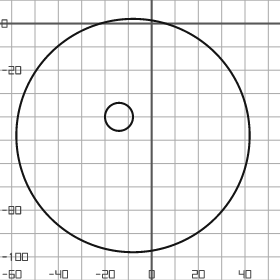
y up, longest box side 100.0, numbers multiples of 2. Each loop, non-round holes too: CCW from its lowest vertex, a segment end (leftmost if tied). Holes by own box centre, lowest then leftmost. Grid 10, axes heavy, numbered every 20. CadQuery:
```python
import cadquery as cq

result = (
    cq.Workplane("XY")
    .moveTo(-8.0, -48.0)
    .circle(50.0)
    .moveTo(-14.0, -40.0)
    .circle(6.0)
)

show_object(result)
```